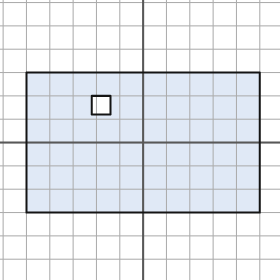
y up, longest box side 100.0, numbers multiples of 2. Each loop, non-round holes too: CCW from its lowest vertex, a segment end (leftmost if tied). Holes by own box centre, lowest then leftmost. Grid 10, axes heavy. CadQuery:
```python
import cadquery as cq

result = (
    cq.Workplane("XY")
    .moveTo(-50.0, -30.0)
    .lineTo(50.0, -30.0)
    .lineTo(50.0, 30.0)
    .lineTo(-50.0, 30.0)
    .close()
    .moveTo(-22.0, 12.0)
    .lineTo(-14.0, 12.0)
    .lineTo(-14.0, 20.0)
    .lineTo(-22.0, 20.0)
    .close()
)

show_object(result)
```